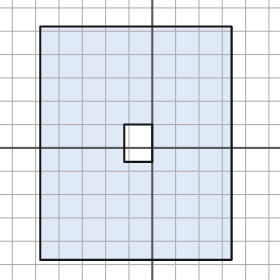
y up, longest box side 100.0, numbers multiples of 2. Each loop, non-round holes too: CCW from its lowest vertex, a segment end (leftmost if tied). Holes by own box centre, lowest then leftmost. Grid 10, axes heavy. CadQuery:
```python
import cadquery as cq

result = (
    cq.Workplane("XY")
    .moveTo(-48.0, -48.0)
    .lineTo(34.0, -48.0)
    .lineTo(34.0, 52.0)
    .lineTo(-48.0, 52.0)
    .close()
    .moveTo(-12.0, -6.0)
    .lineTo(0.0, -6.0)
    .lineTo(0.0, 10.0)
    .lineTo(-12.0, 10.0)
    .close()
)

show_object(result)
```